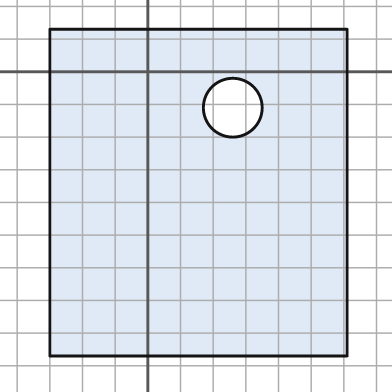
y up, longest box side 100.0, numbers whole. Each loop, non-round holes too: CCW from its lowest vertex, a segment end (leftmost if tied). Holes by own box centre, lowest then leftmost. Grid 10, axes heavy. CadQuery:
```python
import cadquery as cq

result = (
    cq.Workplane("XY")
    .moveTo(-30.0, -87.0)
    .lineTo(61.0, -87.0)
    .lineTo(61.0, 13.0)
    .lineTo(-30.0, 13.0)
    .close()
    .moveTo(26.0, -11.0)
    .circle(9.0)
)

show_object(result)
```